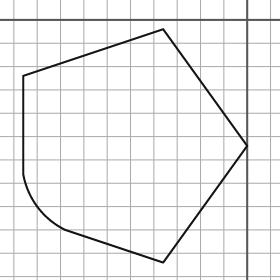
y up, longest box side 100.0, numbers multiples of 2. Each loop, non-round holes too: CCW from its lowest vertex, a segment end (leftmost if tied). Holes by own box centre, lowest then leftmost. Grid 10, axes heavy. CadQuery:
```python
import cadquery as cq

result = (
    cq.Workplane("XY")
    .moveTo(-36.0, -104.0)
    .lineTo(0.0, -54.0)
    .lineTo(-36.0, -4.0)
    .lineTo(-96.0, -24.0)
    .lineTo(-96.0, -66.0)
    .threePointArc((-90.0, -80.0), (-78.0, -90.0))
    .close()
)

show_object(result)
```